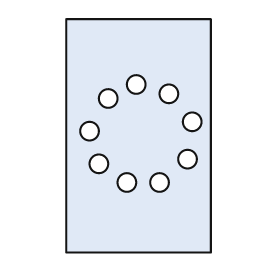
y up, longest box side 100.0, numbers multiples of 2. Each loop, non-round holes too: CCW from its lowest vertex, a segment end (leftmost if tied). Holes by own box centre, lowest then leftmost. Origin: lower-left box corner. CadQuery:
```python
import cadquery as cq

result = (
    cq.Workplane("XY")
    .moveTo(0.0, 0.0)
    .lineTo(62.0, 0.0)
    .lineTo(62.0, 100.0)
    .lineTo(0.0, 100.0)
    .close()
    .moveTo(26.0, 30.0)
    .circle(4.0)
    .moveTo(40.0, 30.0)
    .circle(4.0)
    .moveTo(14.0, 38.0)
    .circle(4.0)
    .moveTo(52.0, 40.0)
    .circle(4.0)
    .moveTo(10.0, 52.0)
    .circle(4.0)
    .moveTo(54.0, 56.0)
    .circle(4.0)
    .moveTo(18.0, 66.0)
    .circle(4.0)
    .moveTo(44.0, 68.0)
    .circle(4.0)
    .moveTo(30.0, 72.0)
    .circle(4.0)
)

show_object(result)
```